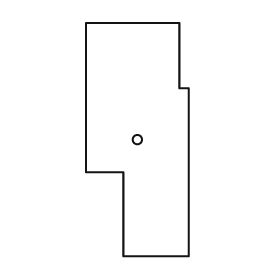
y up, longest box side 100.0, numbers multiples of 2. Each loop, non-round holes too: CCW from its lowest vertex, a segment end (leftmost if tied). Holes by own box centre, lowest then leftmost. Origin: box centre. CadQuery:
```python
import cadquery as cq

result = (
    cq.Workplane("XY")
    .moveTo(-6.0, -50.0)
    .lineTo(22.0, -50.0)
    .lineTo(22.0, 22.0)
    .lineTo(18.0, 22.0)
    .lineTo(18.0, 50.0)
    .lineTo(-22.0, 50.0)
    .lineTo(-22.0, -14.0)
    .lineTo(-6.0, -14.0)
    .close()
    .moveTo(0.0, 0.0)
    .circle(2.0)
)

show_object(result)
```